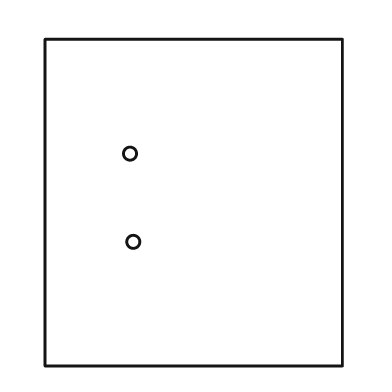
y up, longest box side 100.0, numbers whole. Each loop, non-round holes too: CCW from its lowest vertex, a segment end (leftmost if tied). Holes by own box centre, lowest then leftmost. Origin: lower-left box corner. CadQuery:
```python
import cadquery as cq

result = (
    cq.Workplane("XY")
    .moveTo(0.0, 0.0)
    .lineTo(91.0, 0.0)
    .lineTo(91.0, 100.0)
    .lineTo(0.0, 100.0)
    .close()
    .moveTo(27.0, 38.0)
    .circle(2.0)
    .moveTo(26.0, 65.0)
    .circle(2.0)
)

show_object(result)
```